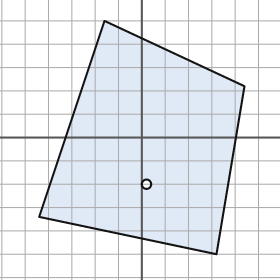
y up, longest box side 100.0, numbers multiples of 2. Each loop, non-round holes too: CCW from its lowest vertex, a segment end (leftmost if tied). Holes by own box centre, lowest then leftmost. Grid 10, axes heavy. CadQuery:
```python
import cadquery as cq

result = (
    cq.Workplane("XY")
    .moveTo(32.0, -50.0)
    .lineTo(44.0, 22.0)
    .lineTo(-16.0, 50.0)
    .lineTo(-44.0, -34.0)
    .close()
    .moveTo(2.0, -20.0)
    .circle(2.0)
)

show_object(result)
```